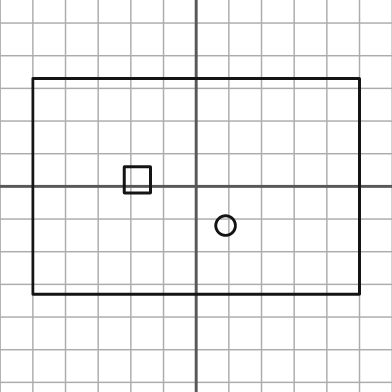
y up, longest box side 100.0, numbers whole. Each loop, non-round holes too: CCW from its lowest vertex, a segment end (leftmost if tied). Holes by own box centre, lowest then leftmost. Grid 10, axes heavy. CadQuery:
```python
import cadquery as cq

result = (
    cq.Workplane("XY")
    .moveTo(-50.0, -33.0)
    .lineTo(50.0, -33.0)
    .lineTo(50.0, 33.0)
    .lineTo(-50.0, 33.0)
    .close()
    .moveTo(9.0, -12.0)
    .circle(3.0)
    .moveTo(-22.0, -2.0)
    .lineTo(-14.0, -2.0)
    .lineTo(-14.0, 6.0)
    .lineTo(-22.0, 6.0)
    .close()
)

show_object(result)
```